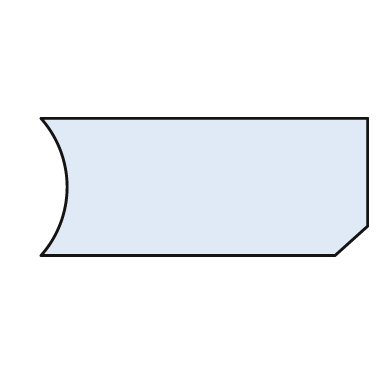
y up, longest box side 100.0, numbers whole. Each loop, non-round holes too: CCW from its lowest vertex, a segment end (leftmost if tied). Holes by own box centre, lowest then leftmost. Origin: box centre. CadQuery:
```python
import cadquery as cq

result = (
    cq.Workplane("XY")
    .moveTo(-50.0, -21.0)
    .lineTo(40.0, -21.0)
    .lineTo(50.0, -12.0)
    .lineTo(50.0, 21.0)
    .lineTo(-50.0, 21.0)
    .threePointArc((-42.0, 0.0), (-50.0, -21.0))
    .close()
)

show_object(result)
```